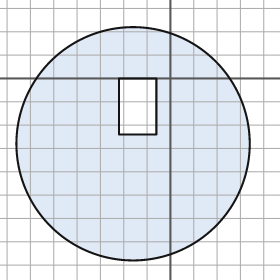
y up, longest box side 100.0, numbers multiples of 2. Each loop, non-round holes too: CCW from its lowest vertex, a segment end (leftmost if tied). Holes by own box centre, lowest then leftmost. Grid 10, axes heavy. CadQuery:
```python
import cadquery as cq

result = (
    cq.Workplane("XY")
    .moveTo(-16.0, -28.0)
    .circle(50.0)
    .moveTo(-22.0, -24.0)
    .lineTo(-6.0, -24.0)
    .lineTo(-6.0, 0.0)
    .lineTo(-22.0, 0.0)
    .close()
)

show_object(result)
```